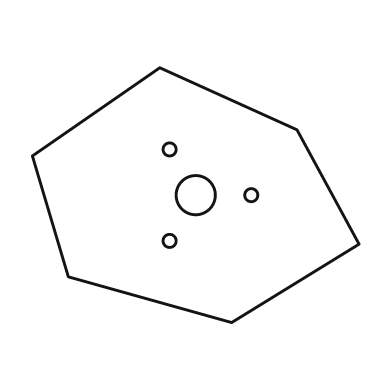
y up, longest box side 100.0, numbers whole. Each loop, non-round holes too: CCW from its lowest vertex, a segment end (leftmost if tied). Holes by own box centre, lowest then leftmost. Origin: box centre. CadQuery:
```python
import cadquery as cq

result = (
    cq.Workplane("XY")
    .moveTo(11.0, -39.0)
    .lineTo(50.0, -15.0)
    .lineTo(31.0, 20.0)
    .lineTo(-11.0, 39.0)
    .lineTo(-50.0, 12.0)
    .lineTo(-39.0, -25.0)
    .close()
    .moveTo(-8.0, -14.0)
    .circle(2.0)
    .moveTo(0.0, 0.0)
    .circle(6.0)
    .moveTo(17.0, 0.0)
    .circle(2.0)
    .moveTo(-8.0, 14.0)
    .circle(2.0)
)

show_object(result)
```